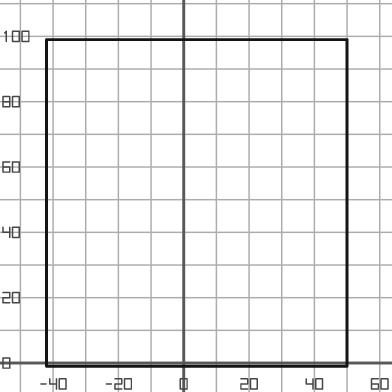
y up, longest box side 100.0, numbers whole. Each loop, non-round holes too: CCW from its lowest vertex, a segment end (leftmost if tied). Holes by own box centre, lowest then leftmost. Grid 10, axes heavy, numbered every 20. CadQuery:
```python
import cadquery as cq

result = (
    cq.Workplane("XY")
    .moveTo(-42.0, -1.0)
    .lineTo(50.0, -1.0)
    .lineTo(50.0, 99.0)
    .lineTo(-42.0, 99.0)
    .close()
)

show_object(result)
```